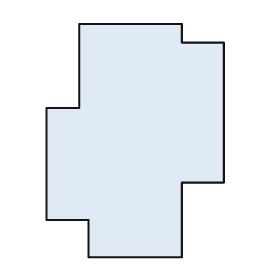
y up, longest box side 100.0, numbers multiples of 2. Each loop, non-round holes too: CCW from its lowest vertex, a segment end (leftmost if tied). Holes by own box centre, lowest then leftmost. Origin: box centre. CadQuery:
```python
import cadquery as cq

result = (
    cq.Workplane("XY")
    .moveTo(-20.0, -50.0)
    .lineTo(20.0, -50.0)
    .lineTo(20.0, -18.0)
    .lineTo(38.0, -18.0)
    .lineTo(38.0, 42.0)
    .lineTo(20.0, 42.0)
    .lineTo(20.0, 50.0)
    .lineTo(-24.0, 50.0)
    .lineTo(-24.0, 14.0)
    .lineTo(-38.0, 14.0)
    .lineTo(-38.0, -34.0)
    .lineTo(-20.0, -34.0)
    .close()
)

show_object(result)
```